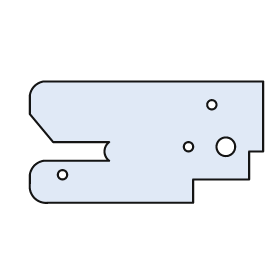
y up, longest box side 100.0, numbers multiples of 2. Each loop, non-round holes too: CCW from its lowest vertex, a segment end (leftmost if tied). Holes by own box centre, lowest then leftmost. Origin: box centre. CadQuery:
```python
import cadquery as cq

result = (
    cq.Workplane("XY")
    .moveTo(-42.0, -26.0)
    .lineTo(20.0, -26.0)
    .lineTo(20.0, -16.0)
    .lineTo(44.0, -16.0)
    .lineTo(44.0, -4.0)
    .lineTo(50.0, -4.0)
    .lineTo(50.0, 26.0)
    .lineTo(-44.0, 26.0)
    .threePointArc((-48.0, 24.0), (-50.0, 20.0))
    .lineTo(-50.0, 12.0)
    .lineTo(-40.0, 0.0)
    .lineTo(-16.0, 0.0)
    .threePointArc((-18.0, -4.0), (-16.0, -8.0))
    .lineTo(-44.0, -8.0)
    .threePointArc((-48.0, -10.0), (-50.0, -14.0))
    .lineTo(-50.0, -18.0)
    .threePointArc((-48.0, -24.0), (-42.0, -26.0))
    .close()
    .moveTo(-36.0, -14.0)
    .circle(2.0)
    .moveTo(18.0, -2.0)
    .circle(2.0)
    .moveTo(34.0, -2.0)
    .circle(4.0)
    .moveTo(28.0, 16.0)
    .circle(2.0)
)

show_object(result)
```